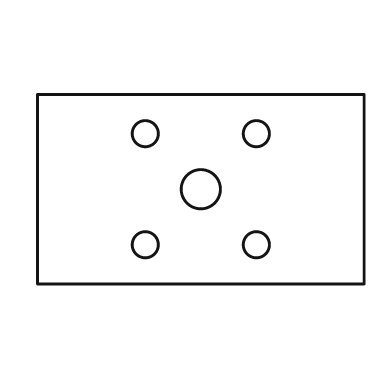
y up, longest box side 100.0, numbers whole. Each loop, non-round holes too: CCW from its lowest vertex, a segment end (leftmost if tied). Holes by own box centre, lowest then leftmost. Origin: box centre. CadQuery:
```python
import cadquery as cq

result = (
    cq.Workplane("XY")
    .moveTo(-50.0, -29.0)
    .lineTo(50.0, -29.0)
    .lineTo(50.0, 29.0)
    .lineTo(-50.0, 29.0)
    .close()
    .moveTo(-17.0, -17.0)
    .circle(4.0)
    .moveTo(17.0, -17.0)
    .circle(4.0)
    .moveTo(0.0, 0.0)
    .circle(6.0)
    .moveTo(-17.0, 17.0)
    .circle(4.0)
    .moveTo(17.0, 17.0)
    .circle(4.0)
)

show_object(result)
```